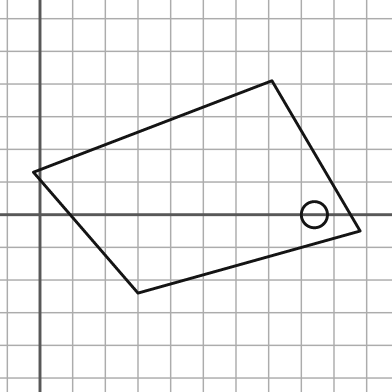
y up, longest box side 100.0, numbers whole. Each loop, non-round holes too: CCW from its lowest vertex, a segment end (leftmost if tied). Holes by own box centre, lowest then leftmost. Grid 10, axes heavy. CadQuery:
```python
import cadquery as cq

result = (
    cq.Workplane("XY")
    .moveTo(30.0, -24.0)
    .lineTo(98.0, -5.0)
    .lineTo(71.0, 41.0)
    .lineTo(-2.0, 13.0)
    .close()
    .moveTo(84.0, 0.0)
    .circle(4.0)
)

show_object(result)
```